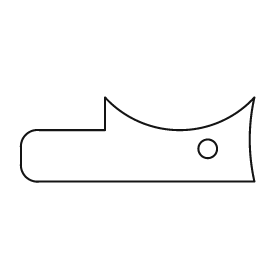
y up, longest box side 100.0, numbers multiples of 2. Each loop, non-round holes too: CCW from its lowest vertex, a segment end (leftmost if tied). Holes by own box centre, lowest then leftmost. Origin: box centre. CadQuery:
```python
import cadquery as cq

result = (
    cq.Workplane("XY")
    .moveTo(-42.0, -18.0)
    .lineTo(50.0, -18.0)
    .threePointArc((48.0, 0.0), (50.0, 18.0))
    .threePointArc((18.0, 4.0), (-14.0, 18.0))
    .lineTo(-14.0, 4.0)
    .lineTo(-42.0, 4.0)
    .threePointArc((-48.0, 2.0), (-50.0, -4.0))
    .lineTo(-50.0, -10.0)
    .threePointArc((-48.0, -16.0), (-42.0, -18.0))
    .close()
    .moveTo(30.0, -4.0)
    .circle(4.0)
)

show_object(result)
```